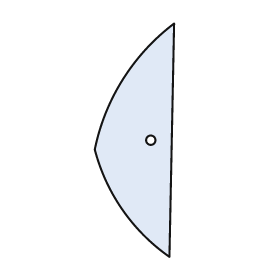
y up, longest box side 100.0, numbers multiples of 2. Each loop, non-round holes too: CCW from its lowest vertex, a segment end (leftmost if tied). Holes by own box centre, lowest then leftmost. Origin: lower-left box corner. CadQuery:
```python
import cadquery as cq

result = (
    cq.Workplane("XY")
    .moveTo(32.0, 0.0)
    .lineTo(34.0, 100.0)
    .threePointArc((12.0, 76.0), (0.0, 46.0))
    .threePointArc((12.0, 20.0), (32.0, 0.0))
    .close()
    .moveTo(24.0, 50.0)
    .circle(2.0)
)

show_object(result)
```